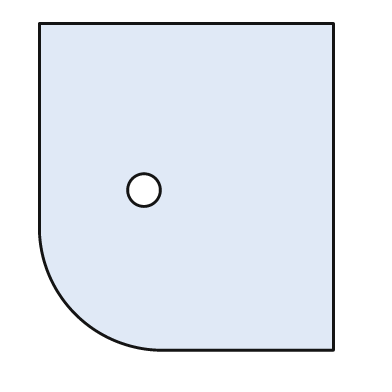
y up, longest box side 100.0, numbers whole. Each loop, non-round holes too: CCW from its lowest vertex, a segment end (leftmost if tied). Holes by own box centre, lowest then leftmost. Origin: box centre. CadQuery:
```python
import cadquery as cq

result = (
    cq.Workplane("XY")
    .moveTo(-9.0, -50.0)
    .lineTo(45.0, -50.0)
    .lineTo(45.0, 50.0)
    .lineTo(-45.0, 50.0)
    .lineTo(-45.0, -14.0)
    .threePointArc((-34.0, -39.0), (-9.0, -50.0))
    .close()
    .moveTo(-13.0, -1.0)
    .circle(5.0)
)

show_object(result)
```